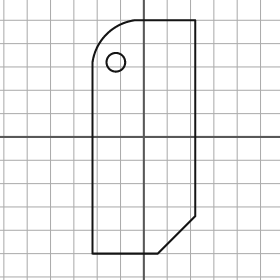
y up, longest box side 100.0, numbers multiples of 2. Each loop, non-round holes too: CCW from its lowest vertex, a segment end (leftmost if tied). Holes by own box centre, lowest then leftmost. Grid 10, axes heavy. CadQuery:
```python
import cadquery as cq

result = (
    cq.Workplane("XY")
    .moveTo(-22.0, -50.0)
    .lineTo(6.0, -50.0)
    .lineTo(22.0, -34.0)
    .lineTo(22.0, 50.0)
    .lineTo(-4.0, 50.0)
    .threePointArc((-16.0, 44.0), (-22.0, 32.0))
    .close()
    .moveTo(-12.0, 32.0)
    .circle(4.0)
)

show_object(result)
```